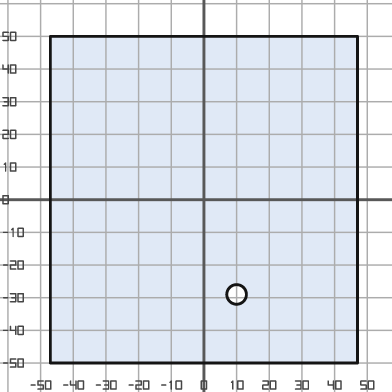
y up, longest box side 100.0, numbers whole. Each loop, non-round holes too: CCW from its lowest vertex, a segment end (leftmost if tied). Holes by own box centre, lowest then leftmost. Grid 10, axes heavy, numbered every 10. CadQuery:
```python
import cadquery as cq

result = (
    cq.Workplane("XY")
    .moveTo(-47.0, -50.0)
    .lineTo(47.0, -50.0)
    .lineTo(47.0, 50.0)
    .lineTo(-47.0, 50.0)
    .close()
    .moveTo(10.0, -29.0)
    .circle(3.0)
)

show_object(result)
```